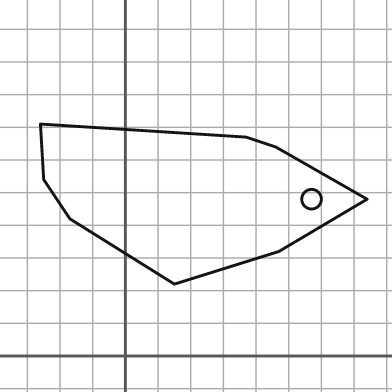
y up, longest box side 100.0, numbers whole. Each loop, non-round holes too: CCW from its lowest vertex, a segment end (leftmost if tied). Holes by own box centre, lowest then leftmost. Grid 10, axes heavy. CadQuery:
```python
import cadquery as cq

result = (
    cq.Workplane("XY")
    .moveTo(15.0, 22.0)
    .lineTo(47.0, 32.0)
    .lineTo(74.0, 48.0)
    .lineTo(46.0, 64.0)
    .lineTo(37.0, 67.0)
    .lineTo(-26.0, 71.0)
    .lineTo(-25.0, 54.0)
    .lineTo(-17.0, 42.0)
    .close()
    .moveTo(57.0, 48.0)
    .circle(3.0)
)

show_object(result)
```